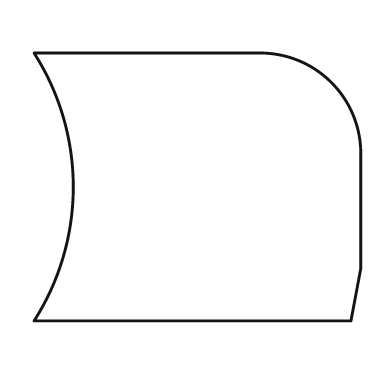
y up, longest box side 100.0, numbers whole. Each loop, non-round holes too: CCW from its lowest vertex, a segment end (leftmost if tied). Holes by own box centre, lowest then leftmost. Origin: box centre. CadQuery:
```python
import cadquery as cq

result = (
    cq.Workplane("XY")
    .moveTo(-50.0, -41.0)
    .lineTo(47.0, -41.0)
    .lineTo(50.0, -25.0)
    .lineTo(50.0, 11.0)
    .threePointArc((41.0, 32.0), (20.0, 41.0))
    .lineTo(-50.0, 41.0)
    .threePointArc((-38.0, 0.0), (-50.0, -41.0))
    .close()
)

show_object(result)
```